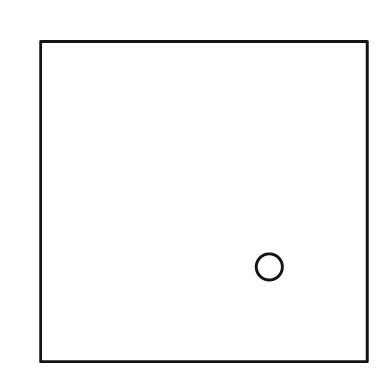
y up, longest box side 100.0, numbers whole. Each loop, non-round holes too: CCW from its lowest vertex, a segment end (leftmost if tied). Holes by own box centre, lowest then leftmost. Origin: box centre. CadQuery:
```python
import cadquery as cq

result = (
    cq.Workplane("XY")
    .moveTo(-50.0, -49.0)
    .lineTo(50.0, -49.0)
    .lineTo(50.0, 49.0)
    .lineTo(-50.0, 49.0)
    .close()
    .moveTo(20.0, -20.0)
    .circle(4.0)
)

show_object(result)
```